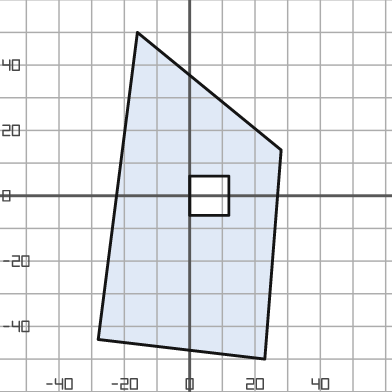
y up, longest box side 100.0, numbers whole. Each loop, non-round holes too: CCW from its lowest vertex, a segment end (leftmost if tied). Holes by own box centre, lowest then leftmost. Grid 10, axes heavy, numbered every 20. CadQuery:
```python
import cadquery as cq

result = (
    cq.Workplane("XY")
    .moveTo(23.0, -50.0)
    .lineTo(28.0, 14.0)
    .lineTo(-16.0, 50.0)
    .lineTo(-28.0, -44.0)
    .close()
    .moveTo(0.0, -6.0)
    .lineTo(12.0, -6.0)
    .lineTo(12.0, 6.0)
    .lineTo(0.0, 6.0)
    .close()
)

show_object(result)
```